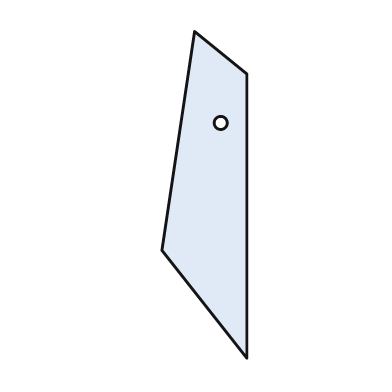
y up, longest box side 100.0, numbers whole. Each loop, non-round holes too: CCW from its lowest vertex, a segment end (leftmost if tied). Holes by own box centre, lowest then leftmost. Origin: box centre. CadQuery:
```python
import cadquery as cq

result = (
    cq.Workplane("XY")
    .moveTo(13.0, -50.0)
    .lineTo(13.0, 37.0)
    .lineTo(-3.0, 50.0)
    .lineTo(-13.0, -17.0)
    .close()
    .moveTo(5.0, 22.0)
    .circle(2.0)
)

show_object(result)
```